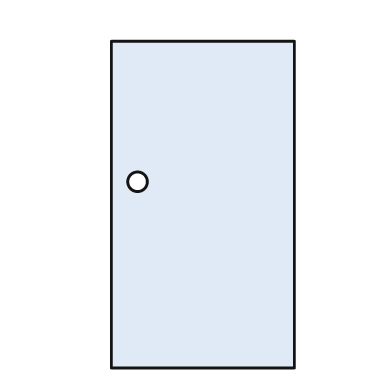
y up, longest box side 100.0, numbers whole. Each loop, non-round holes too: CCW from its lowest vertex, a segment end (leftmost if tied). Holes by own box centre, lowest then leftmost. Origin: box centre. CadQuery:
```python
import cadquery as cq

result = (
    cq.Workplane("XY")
    .moveTo(-28.0, -50.0)
    .lineTo(28.0, -50.0)
    .lineTo(28.0, 50.0)
    .lineTo(-28.0, 50.0)
    .close()
    .moveTo(-20.0, 7.0)
    .circle(3.0)
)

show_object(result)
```